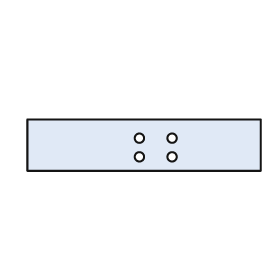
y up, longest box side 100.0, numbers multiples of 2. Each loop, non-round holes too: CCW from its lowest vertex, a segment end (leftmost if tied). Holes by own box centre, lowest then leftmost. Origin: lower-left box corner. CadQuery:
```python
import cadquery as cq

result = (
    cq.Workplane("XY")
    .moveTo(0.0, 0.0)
    .lineTo(100.0, 0.0)
    .lineTo(100.0, 22.0)
    .lineTo(0.0, 22.0)
    .close()
    .moveTo(48.0, 6.0)
    .circle(2.0)
    .moveTo(62.0, 6.0)
    .circle(2.0)
    .moveTo(48.0, 14.0)
    .circle(2.0)
    .moveTo(62.0, 14.0)
    .circle(2.0)
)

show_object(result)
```